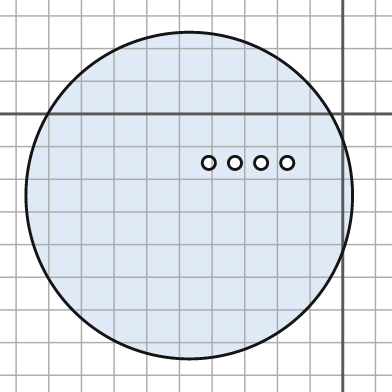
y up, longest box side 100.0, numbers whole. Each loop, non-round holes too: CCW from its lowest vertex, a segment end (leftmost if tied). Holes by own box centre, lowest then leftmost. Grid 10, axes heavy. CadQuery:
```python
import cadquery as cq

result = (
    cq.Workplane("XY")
    .moveTo(-47.0, -25.0)
    .circle(50.0)
    .moveTo(-41.0, -15.0)
    .circle(2.0)
    .moveTo(-33.0, -15.0)
    .circle(2.0)
    .moveTo(-25.0, -15.0)
    .circle(2.0)
    .moveTo(-17.0, -15.0)
    .circle(2.0)
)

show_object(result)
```